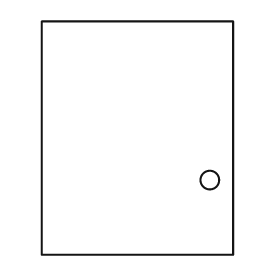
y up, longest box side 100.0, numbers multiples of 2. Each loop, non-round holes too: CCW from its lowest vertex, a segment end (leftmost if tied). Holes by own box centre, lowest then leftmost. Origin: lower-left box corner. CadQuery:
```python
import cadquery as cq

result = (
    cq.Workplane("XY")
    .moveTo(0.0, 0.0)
    .lineTo(82.0, 0.0)
    .lineTo(82.0, 100.0)
    .lineTo(0.0, 100.0)
    .close()
    .moveTo(72.0, 32.0)
    .circle(4.0)
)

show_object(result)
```